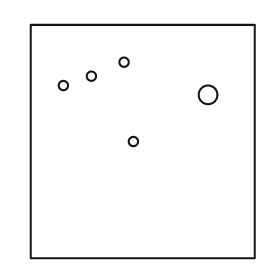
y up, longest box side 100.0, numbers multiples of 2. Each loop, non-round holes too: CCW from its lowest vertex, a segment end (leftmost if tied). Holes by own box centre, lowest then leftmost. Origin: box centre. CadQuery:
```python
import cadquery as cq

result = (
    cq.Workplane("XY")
    .moveTo(-48.0, -50.0)
    .lineTo(48.0, -50.0)
    .lineTo(48.0, 50.0)
    .lineTo(-48.0, 50.0)
    .close()
    .moveTo(-4.0, 0.0)
    .circle(2.0)
    .moveTo(28.0, 20.0)
    .circle(4.0)
    .moveTo(-34.0, 24.0)
    .circle(2.0)
    .moveTo(-22.0, 28.0)
    .circle(2.0)
    .moveTo(-8.0, 34.0)
    .circle(2.0)
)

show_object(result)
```